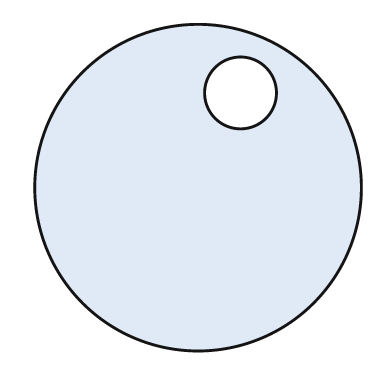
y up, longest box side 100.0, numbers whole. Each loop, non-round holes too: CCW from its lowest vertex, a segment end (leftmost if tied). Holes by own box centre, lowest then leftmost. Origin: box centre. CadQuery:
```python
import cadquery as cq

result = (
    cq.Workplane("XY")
    .moveTo(0.0, 0.0)
    .circle(50.0)
    .moveTo(13.0, 29.0)
    .circle(11.0)
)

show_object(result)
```